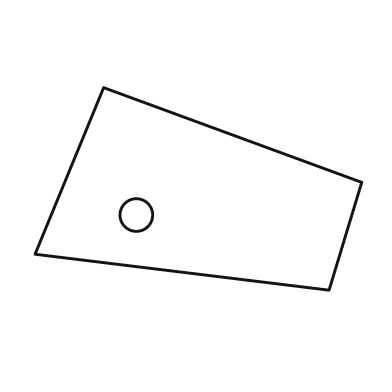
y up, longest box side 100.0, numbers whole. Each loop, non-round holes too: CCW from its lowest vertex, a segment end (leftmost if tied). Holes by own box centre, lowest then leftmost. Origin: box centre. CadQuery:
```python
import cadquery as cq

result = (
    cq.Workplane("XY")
    .moveTo(40.0, -31.0)
    .lineTo(50.0, 2.0)
    .lineTo(-29.0, 31.0)
    .lineTo(-50.0, -20.0)
    .close()
    .moveTo(-19.0, -8.0)
    .circle(5.0)
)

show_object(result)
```